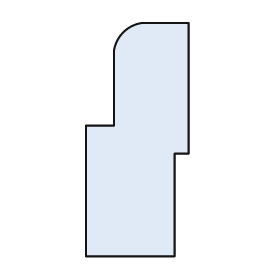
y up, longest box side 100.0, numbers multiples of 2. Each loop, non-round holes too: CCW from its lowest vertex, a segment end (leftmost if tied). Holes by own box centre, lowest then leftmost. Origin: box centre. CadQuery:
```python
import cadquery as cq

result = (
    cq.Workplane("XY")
    .moveTo(-22.0, -50.0)
    .lineTo(16.0, -50.0)
    .lineTo(16.0, -6.0)
    .lineTo(22.0, -6.0)
    .lineTo(22.0, 50.0)
    .lineTo(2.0, 50.0)
    .threePointArc((-6.0, 46.0), (-10.0, 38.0))
    .lineTo(-10.0, 6.0)
    .lineTo(-22.0, 6.0)
    .close()
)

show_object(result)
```